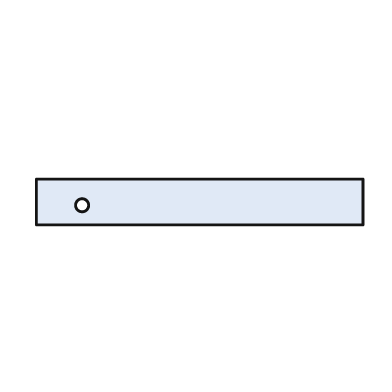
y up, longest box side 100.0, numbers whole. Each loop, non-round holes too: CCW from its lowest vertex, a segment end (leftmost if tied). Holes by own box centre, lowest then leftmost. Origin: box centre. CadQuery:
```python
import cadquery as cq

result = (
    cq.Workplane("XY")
    .moveTo(-50.0, -7.0)
    .lineTo(50.0, -7.0)
    .lineTo(50.0, 7.0)
    .lineTo(-50.0, 7.0)
    .close()
    .moveTo(-36.0, -1.0)
    .circle(2.0)
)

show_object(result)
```